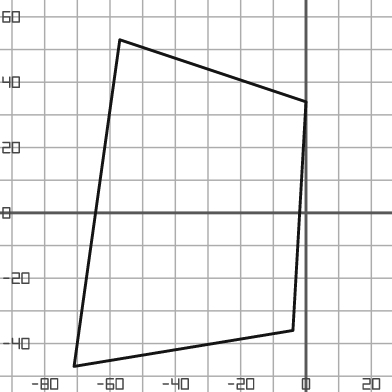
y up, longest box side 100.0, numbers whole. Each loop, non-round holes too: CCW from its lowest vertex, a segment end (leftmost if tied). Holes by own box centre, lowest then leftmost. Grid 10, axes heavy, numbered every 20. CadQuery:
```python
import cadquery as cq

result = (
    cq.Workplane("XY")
    .moveTo(-71.0, -47.0)
    .lineTo(-4.0, -36.0)
    .lineTo(0.0, 34.0)
    .lineTo(-57.0, 53.0)
    .close()
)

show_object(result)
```